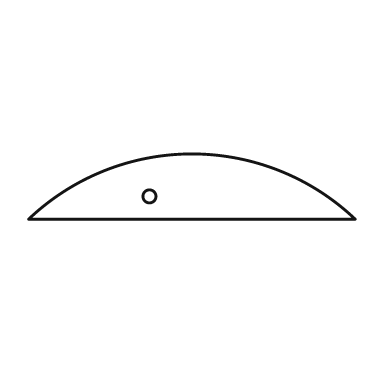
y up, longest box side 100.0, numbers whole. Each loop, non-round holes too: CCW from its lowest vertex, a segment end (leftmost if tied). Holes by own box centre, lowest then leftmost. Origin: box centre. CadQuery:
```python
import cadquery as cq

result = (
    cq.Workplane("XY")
    .moveTo(-50.0, -10.0)
    .lineTo(50.0, -10.0)
    .threePointArc((0.0, 10.0), (-50.0, -10.0))
    .close()
    .moveTo(-13.0, -3.0)
    .circle(2.0)
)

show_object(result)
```